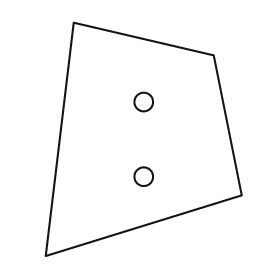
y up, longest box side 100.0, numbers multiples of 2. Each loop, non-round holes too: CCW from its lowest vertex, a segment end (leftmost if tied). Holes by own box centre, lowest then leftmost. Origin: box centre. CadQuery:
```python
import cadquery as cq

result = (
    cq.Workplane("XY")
    .moveTo(-42.0, -50.0)
    .lineTo(42.0, -24.0)
    .lineTo(30.0, 36.0)
    .lineTo(-30.0, 50.0)
    .close()
    .moveTo(0.0, -16.0)
    .circle(4.0)
    .moveTo(0.0, 16.0)
    .circle(4.0)
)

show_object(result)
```